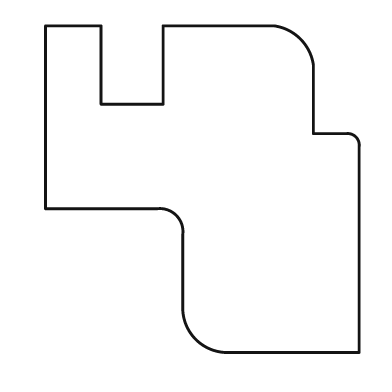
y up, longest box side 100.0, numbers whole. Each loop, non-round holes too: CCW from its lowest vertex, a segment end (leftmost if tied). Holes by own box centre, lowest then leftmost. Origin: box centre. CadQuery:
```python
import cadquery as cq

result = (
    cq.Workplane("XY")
    .moveTo(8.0, -50.0)
    .lineTo(48.0, -50.0)
    .lineTo(48.0, 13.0)
    .threePointArc((47.0, 16.0), (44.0, 17.0))
    .lineTo(34.0, 17.0)
    .lineTo(34.0, 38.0)
    .threePointArc((30.0, 46.0), (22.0, 50.0))
    .lineTo(-12.0, 50.0)
    .lineTo(-12.0, 26.0)
    .lineTo(-31.0, 26.0)
    .lineTo(-31.0, 50.0)
    .lineTo(-48.0, 50.0)
    .lineTo(-48.0, -6.0)
    .lineTo(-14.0, -6.0)
    .threePointArc((-8.0, -8.0), (-6.0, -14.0))
    .lineTo(-6.0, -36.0)
    .threePointArc((-2.0, -46.0), (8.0, -50.0))
    .close()
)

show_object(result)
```